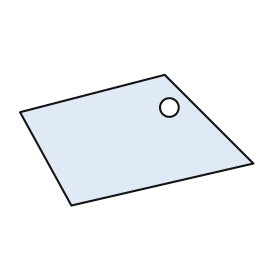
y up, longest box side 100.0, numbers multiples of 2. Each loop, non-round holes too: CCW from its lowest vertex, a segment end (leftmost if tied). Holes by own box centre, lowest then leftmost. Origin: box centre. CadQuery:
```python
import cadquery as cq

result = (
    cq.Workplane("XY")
    .moveTo(-28.0, -28.0)
    .lineTo(50.0, -10.0)
    .lineTo(12.0, 28.0)
    .lineTo(-50.0, 12.0)
    .close()
    .moveTo(14.0, 14.0)
    .circle(4.0)
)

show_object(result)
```